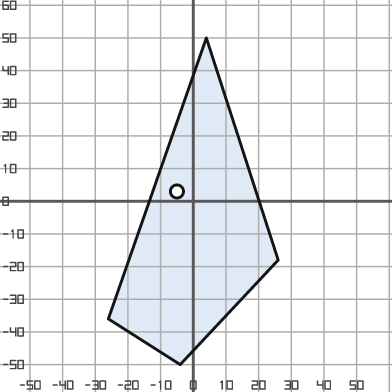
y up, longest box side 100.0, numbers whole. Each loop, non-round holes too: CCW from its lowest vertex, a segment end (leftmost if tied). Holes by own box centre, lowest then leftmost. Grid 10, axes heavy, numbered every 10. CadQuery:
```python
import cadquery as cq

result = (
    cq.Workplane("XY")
    .moveTo(-4.0, -50.0)
    .lineTo(26.0, -18.0)
    .lineTo(4.0, 50.0)
    .lineTo(-26.0, -36.0)
    .close()
    .moveTo(-5.0, 3.0)
    .circle(2.0)
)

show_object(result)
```